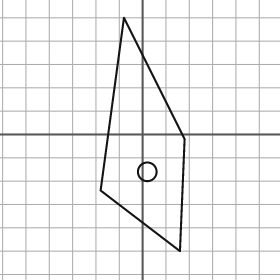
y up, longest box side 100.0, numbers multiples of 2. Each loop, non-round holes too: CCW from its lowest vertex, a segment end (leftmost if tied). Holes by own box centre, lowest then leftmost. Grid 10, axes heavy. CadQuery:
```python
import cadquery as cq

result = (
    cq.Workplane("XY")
    .moveTo(16.0, -50.0)
    .lineTo(18.0, -2.0)
    .lineTo(-8.0, 50.0)
    .lineTo(-18.0, -24.0)
    .close()
    .moveTo(2.0, -16.0)
    .circle(4.0)
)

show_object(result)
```